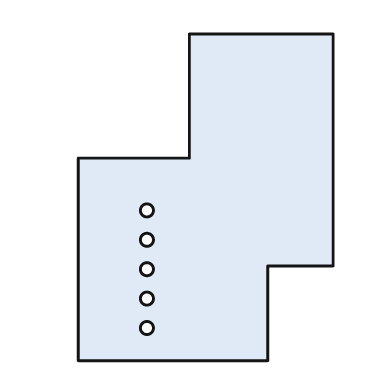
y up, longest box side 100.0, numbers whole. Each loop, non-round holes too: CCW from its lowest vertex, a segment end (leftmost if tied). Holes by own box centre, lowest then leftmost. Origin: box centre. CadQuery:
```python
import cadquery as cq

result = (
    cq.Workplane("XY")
    .moveTo(-39.0, -50.0)
    .lineTo(19.0, -50.0)
    .lineTo(19.0, -21.0)
    .lineTo(39.0, -21.0)
    .lineTo(39.0, 50.0)
    .lineTo(-5.0, 50.0)
    .lineTo(-5.0, 12.0)
    .lineTo(-39.0, 12.0)
    .close()
    .moveTo(-18.0, -40.0)
    .circle(2.0)
    .moveTo(-18.0, -31.0)
    .circle(2.0)
    .moveTo(-18.0, -22.0)
    .circle(2.0)
    .moveTo(-18.0, -13.0)
    .circle(2.0)
    .moveTo(-18.0, -4.0)
    .circle(2.0)
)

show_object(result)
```